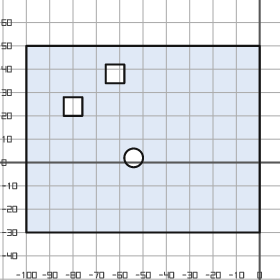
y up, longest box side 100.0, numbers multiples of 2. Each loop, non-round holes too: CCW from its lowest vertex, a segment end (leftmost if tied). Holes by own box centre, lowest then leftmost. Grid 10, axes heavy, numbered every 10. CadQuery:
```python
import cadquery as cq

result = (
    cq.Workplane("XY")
    .moveTo(-100.0, -30.0)
    .lineTo(0.0, -30.0)
    .lineTo(0.0, 50.0)
    .lineTo(-100.0, 50.0)
    .close()
    .moveTo(-54.0, 2.0)
    .circle(4.0)
    .moveTo(-84.0, 20.0)
    .lineTo(-76.0, 20.0)
    .lineTo(-76.0, 28.0)
    .lineTo(-84.0, 28.0)
    .close()
    .moveTo(-66.0, 34.0)
    .lineTo(-58.0, 34.0)
    .lineTo(-58.0, 42.0)
    .lineTo(-66.0, 42.0)
    .close()
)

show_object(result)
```